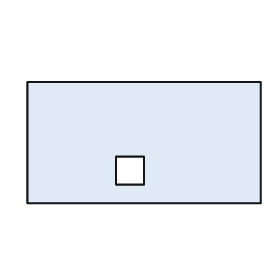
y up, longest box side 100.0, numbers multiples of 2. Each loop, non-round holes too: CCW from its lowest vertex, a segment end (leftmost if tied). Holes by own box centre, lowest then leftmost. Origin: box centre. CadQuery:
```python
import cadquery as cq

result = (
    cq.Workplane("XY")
    .moveTo(-50.0, -26.0)
    .lineTo(50.0, -26.0)
    .lineTo(50.0, 26.0)
    .lineTo(-50.0, 26.0)
    .close()
    .moveTo(-12.0, -18.0)
    .lineTo(0.0, -18.0)
    .lineTo(0.0, -6.0)
    .lineTo(-12.0, -6.0)
    .close()
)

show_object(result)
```